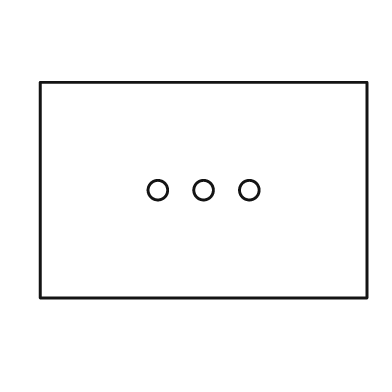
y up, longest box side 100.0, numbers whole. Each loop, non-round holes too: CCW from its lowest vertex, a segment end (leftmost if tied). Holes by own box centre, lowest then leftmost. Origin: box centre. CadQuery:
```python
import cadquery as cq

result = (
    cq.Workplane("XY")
    .moveTo(-50.0, -33.0)
    .lineTo(50.0, -33.0)
    .lineTo(50.0, 33.0)
    .lineTo(-50.0, 33.0)
    .close()
    .moveTo(-14.0, 0.0)
    .circle(3.0)
    .moveTo(0.0, 0.0)
    .circle(3.0)
    .moveTo(14.0, 0.0)
    .circle(3.0)
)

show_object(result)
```